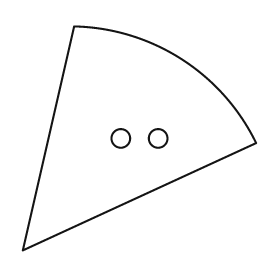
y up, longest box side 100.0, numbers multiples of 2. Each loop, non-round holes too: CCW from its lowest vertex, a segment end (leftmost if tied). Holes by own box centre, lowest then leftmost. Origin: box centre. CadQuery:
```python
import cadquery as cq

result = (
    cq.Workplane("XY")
    .moveTo(-50.0, -48.0)
    .lineTo(50.0, -2.0)
    .threePointArc((18.0, 34.0), (-28.0, 48.0))
    .close()
    .moveTo(-8.0, 0.0)
    .circle(4.0)
    .moveTo(8.0, 0.0)
    .circle(4.0)
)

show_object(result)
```